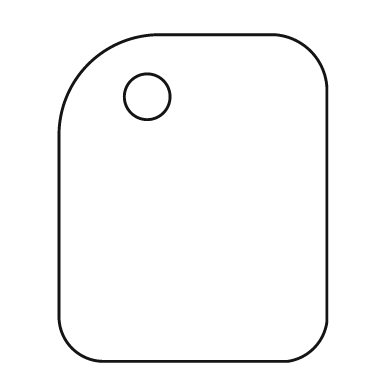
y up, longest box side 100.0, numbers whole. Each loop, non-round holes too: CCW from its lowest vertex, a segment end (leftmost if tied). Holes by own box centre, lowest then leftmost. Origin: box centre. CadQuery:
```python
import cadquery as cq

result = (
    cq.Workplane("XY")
    .moveTo(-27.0, -50.0)
    .lineTo(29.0, -50.0)
    .threePointArc((37.0, -46.0), (41.0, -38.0))
    .lineTo(41.0, 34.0)
    .threePointArc((36.0, 45.0), (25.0, 50.0))
    .lineTo(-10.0, 50.0)
    .threePointArc((-32.0, 41.0), (-41.0, 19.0))
    .lineTo(-41.0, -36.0)
    .threePointArc((-37.0, -46.0), (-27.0, -50.0))
    .close()
    .moveTo(-14.0, 31.0)
    .circle(7.0)
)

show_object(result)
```